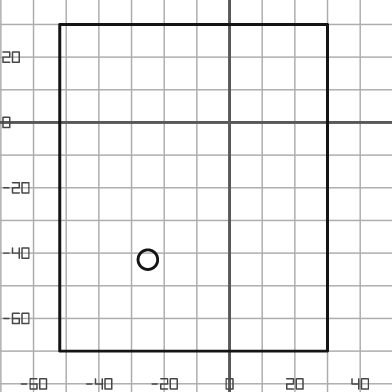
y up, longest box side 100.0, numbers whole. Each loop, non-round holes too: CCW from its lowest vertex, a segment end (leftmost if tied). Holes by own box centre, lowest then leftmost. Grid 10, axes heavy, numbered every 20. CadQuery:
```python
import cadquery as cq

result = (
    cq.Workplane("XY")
    .moveTo(-52.0, -70.0)
    .lineTo(30.0, -70.0)
    .lineTo(30.0, 30.0)
    .lineTo(-52.0, 30.0)
    .close()
    .moveTo(-25.0, -42.0)
    .circle(3.0)
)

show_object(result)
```